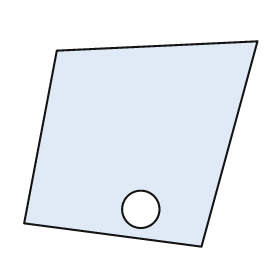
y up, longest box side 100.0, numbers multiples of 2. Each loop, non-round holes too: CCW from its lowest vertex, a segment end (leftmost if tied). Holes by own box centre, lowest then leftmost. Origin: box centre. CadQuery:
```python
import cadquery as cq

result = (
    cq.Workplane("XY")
    .moveTo(26.0, -44.0)
    .lineTo(50.0, 44.0)
    .lineTo(-36.0, 40.0)
    .lineTo(-50.0, -34.0)
    .close()
    .moveTo(0.0, -28.0)
    .circle(8.0)
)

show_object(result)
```